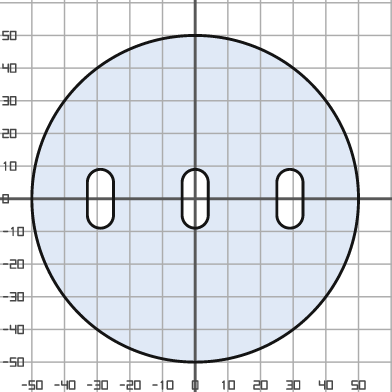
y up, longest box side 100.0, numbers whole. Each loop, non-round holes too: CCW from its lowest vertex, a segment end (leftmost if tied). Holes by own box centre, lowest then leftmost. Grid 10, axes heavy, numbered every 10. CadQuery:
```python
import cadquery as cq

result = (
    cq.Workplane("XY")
    .moveTo(0.0, 0.0)
    .circle(50.0)
    .moveTo(-33.0, -5.0)
    .threePointArc((-29.0, -9.0), (-25.0, -5.0))
    .lineTo(-25.0, 5.0)
    .threePointArc((-29.0, 9.0), (-33.0, 5.0))
    .close()
    .moveTo(-4.0, -5.0)
    .threePointArc((0.0, -9.0), (4.0, -5.0))
    .lineTo(4.0, 5.0)
    .threePointArc((0.0, 9.0), (-4.0, 5.0))
    .close()
    .moveTo(25.0, -5.0)
    .threePointArc((29.0, -9.0), (33.0, -5.0))
    .lineTo(33.0, 5.0)
    .threePointArc((29.0, 9.0), (25.0, 5.0))
    .close()
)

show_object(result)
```